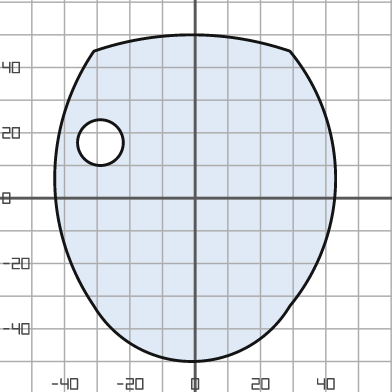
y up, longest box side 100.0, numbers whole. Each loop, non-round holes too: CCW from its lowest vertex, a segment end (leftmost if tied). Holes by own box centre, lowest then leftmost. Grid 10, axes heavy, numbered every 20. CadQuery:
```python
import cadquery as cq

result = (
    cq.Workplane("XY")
    .moveTo(-31.0, -33.0)
    .threePointArc((-1.0, -50.0), (29.0, -33.0))
    .threePointArc((43.0, 6.0), (29.0, 45.0))
    .threePointArc((-1.0, 50.0), (-31.0, 45.0))
    .threePointArc((-43.0, 6.0), (-31.0, -33.0))
    .close()
    .moveTo(-29.0, 17.0)
    .circle(7.0)
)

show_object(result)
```